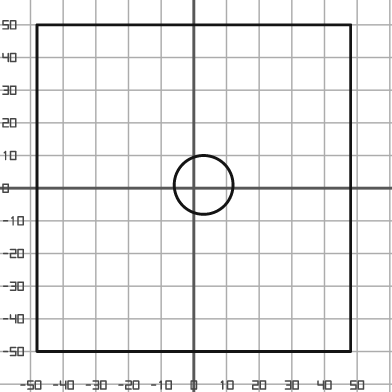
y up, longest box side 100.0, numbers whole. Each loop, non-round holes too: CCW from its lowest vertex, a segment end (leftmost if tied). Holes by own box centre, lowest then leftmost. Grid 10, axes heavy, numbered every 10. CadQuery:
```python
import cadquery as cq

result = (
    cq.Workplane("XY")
    .moveTo(-48.0, -50.0)
    .lineTo(48.0, -50.0)
    .lineTo(48.0, 50.0)
    .lineTo(-48.0, 50.0)
    .close()
    .moveTo(3.0, 1.0)
    .circle(9.0)
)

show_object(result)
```